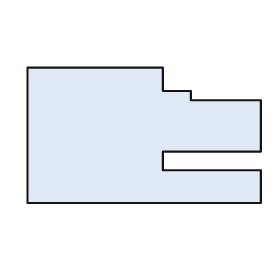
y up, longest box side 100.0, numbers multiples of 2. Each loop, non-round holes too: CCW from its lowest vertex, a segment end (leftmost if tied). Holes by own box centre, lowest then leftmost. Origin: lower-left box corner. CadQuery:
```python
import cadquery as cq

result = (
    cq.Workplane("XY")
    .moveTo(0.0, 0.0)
    .lineTo(100.0, 0.0)
    .lineTo(100.0, 14.0)
    .lineTo(58.0, 14.0)
    .lineTo(58.0, 22.0)
    .lineTo(100.0, 22.0)
    .lineTo(100.0, 44.0)
    .lineTo(70.0, 44.0)
    .lineTo(70.0, 48.0)
    .lineTo(58.0, 48.0)
    .lineTo(58.0, 58.0)
    .lineTo(0.0, 58.0)
    .close()
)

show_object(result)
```